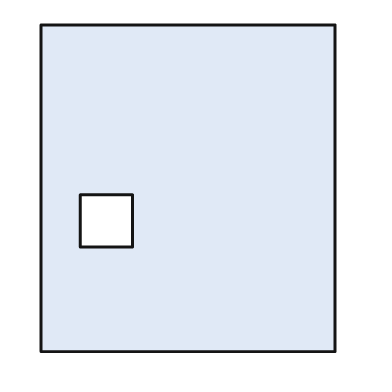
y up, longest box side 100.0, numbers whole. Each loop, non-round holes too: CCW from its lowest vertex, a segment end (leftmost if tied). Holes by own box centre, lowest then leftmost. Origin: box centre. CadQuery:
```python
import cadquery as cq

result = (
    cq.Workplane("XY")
    .moveTo(-45.0, -50.0)
    .lineTo(45.0, -50.0)
    .lineTo(45.0, 50.0)
    .lineTo(-45.0, 50.0)
    .close()
    .moveTo(-33.0, -18.0)
    .lineTo(-17.0, -18.0)
    .lineTo(-17.0, -2.0)
    .lineTo(-33.0, -2.0)
    .close()
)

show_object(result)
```